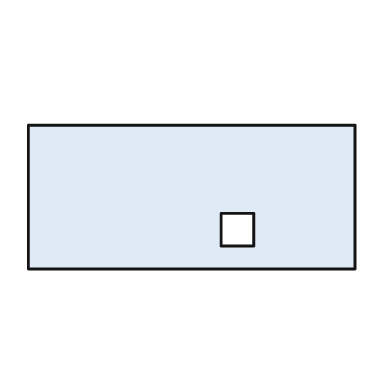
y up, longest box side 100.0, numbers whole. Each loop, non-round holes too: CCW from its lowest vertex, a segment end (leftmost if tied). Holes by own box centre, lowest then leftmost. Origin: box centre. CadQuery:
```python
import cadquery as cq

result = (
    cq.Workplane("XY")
    .moveTo(-50.0, -22.0)
    .lineTo(50.0, -22.0)
    .lineTo(50.0, 22.0)
    .lineTo(-50.0, 22.0)
    .close()
    .moveTo(9.0, -15.0)
    .lineTo(19.0, -15.0)
    .lineTo(19.0, -5.0)
    .lineTo(9.0, -5.0)
    .close()
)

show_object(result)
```